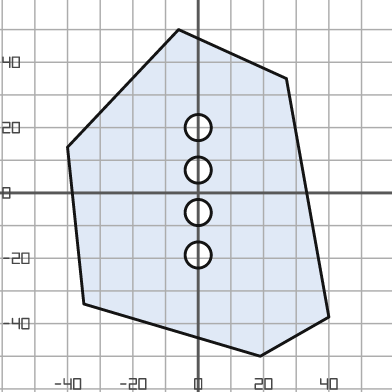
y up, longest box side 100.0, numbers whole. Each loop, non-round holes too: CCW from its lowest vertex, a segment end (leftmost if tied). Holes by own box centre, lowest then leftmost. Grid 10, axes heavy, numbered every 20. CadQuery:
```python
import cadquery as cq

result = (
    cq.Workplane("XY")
    .moveTo(19.0, -50.0)
    .lineTo(40.0, -38.0)
    .lineTo(27.0, 35.0)
    .lineTo(-6.0, 50.0)
    .lineTo(-40.0, 14.0)
    .lineTo(-35.0, -34.0)
    .close()
    .moveTo(0.0, -19.0)
    .circle(4.0)
    .moveTo(0.0, -6.0)
    .circle(4.0)
    .moveTo(0.0, 7.0)
    .circle(4.0)
    .moveTo(0.0, 20.0)
    .circle(4.0)
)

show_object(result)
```